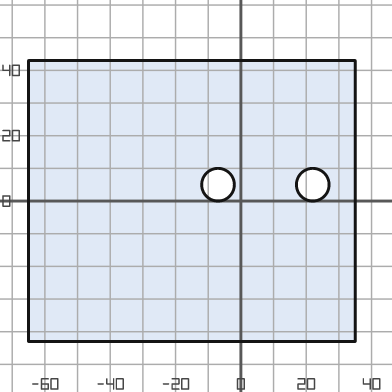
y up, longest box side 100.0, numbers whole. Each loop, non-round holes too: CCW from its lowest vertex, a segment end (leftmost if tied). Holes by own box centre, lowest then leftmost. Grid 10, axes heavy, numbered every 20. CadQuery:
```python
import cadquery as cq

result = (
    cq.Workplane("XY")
    .moveTo(-65.0, -43.0)
    .lineTo(35.0, -43.0)
    .lineTo(35.0, 43.0)
    .lineTo(-65.0, 43.0)
    .close()
    .moveTo(-7.0, 5.0)
    .circle(5.0)
    .moveTo(22.0, 5.0)
    .circle(5.0)
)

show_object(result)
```